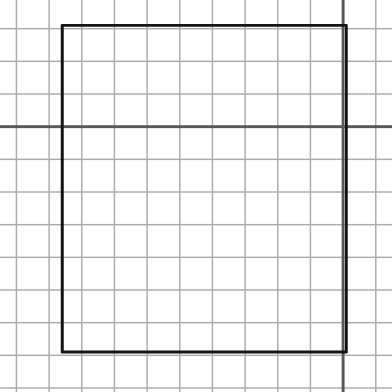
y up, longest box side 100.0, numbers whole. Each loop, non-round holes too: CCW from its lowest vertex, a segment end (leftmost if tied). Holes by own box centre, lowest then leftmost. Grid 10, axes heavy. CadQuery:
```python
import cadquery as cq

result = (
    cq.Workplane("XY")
    .moveTo(-86.0, -69.0)
    .lineTo(1.0, -69.0)
    .lineTo(1.0, 31.0)
    .lineTo(-86.0, 31.0)
    .close()
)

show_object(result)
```